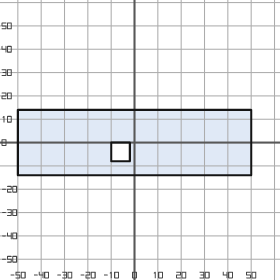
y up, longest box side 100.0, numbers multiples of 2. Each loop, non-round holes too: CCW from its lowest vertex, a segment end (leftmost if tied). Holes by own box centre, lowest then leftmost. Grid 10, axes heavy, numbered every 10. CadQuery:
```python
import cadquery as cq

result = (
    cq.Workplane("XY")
    .moveTo(-50.0, -14.0)
    .lineTo(50.0, -14.0)
    .lineTo(50.0, 14.0)
    .lineTo(-50.0, 14.0)
    .close()
    .moveTo(-10.0, -8.0)
    .lineTo(-2.0, -8.0)
    .lineTo(-2.0, 0.0)
    .lineTo(-10.0, 0.0)
    .close()
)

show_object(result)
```